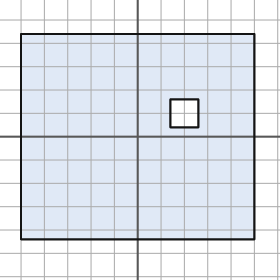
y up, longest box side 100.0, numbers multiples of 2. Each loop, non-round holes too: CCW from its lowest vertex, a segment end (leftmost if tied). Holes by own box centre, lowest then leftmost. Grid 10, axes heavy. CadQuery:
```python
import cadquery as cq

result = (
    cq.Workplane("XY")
    .moveTo(-50.0, -44.0)
    .lineTo(50.0, -44.0)
    .lineTo(50.0, 44.0)
    .lineTo(-50.0, 44.0)
    .close()
    .moveTo(14.0, 4.0)
    .lineTo(26.0, 4.0)
    .lineTo(26.0, 16.0)
    .lineTo(14.0, 16.0)
    .close()
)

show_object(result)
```